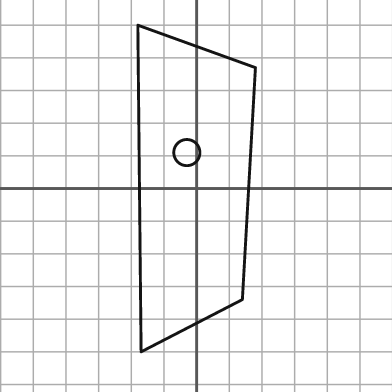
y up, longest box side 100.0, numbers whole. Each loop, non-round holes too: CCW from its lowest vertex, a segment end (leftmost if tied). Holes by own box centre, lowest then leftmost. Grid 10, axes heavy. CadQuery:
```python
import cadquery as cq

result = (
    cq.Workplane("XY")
    .moveTo(-17.0, -50.0)
    .lineTo(14.0, -34.0)
    .lineTo(18.0, 37.0)
    .lineTo(-18.0, 50.0)
    .close()
    .moveTo(-3.0, 11.0)
    .circle(4.0)
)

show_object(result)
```